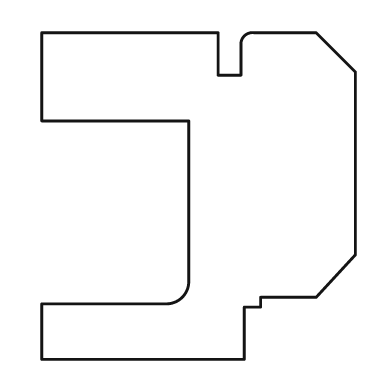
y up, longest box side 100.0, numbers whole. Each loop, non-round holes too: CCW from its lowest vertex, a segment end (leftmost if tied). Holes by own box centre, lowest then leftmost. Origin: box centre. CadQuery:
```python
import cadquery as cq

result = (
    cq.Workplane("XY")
    .moveTo(-48.0, -50.0)
    .lineTo(14.0, -50.0)
    .lineTo(14.0, -34.0)
    .lineTo(19.0, -34.0)
    .lineTo(19.0, -31.0)
    .lineTo(36.0, -31.0)
    .lineTo(48.0, -18.0)
    .lineTo(48.0, 38.0)
    .lineTo(36.0, 50.0)
    .lineTo(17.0, 50.0)
    .threePointArc((14.0, 49.0), (13.0, 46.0))
    .lineTo(13.0, 37.0)
    .lineTo(6.0, 37.0)
    .lineTo(6.0, 50.0)
    .lineTo(-48.0, 50.0)
    .lineTo(-48.0, 23.0)
    .lineTo(-3.0, 23.0)
    .lineTo(-3.0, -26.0)
    .threePointArc((-5.0, -31.0), (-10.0, -33.0))
    .lineTo(-48.0, -33.0)
    .close()
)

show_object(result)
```